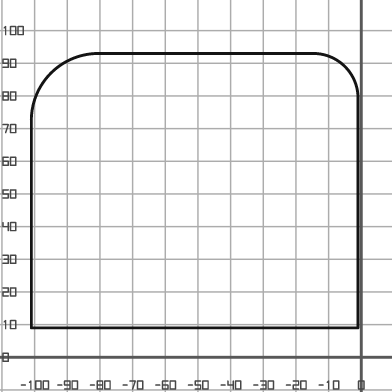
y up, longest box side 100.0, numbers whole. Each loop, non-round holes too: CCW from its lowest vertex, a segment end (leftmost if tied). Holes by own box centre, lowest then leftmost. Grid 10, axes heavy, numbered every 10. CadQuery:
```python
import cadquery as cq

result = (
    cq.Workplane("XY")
    .moveTo(-101.0, 9.0)
    .lineTo(-1.0, 9.0)
    .lineTo(-1.0, 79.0)
    .threePointArc((-5.0, 89.0), (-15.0, 93.0))
    .lineTo(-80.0, 93.0)
    .threePointArc((-95.0, 87.0), (-101.0, 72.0))
    .close()
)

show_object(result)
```